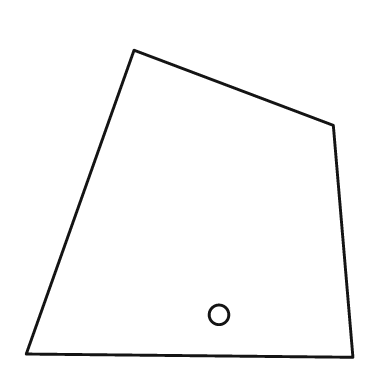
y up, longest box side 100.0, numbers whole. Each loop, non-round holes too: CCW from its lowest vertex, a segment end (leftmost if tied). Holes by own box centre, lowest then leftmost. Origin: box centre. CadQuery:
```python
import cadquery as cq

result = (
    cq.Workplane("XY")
    .moveTo(50.0, -47.0)
    .lineTo(44.0, 24.0)
    .lineTo(-17.0, 47.0)
    .lineTo(-50.0, -46.0)
    .close()
    .moveTo(9.0, -34.0)
    .circle(3.0)
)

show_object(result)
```